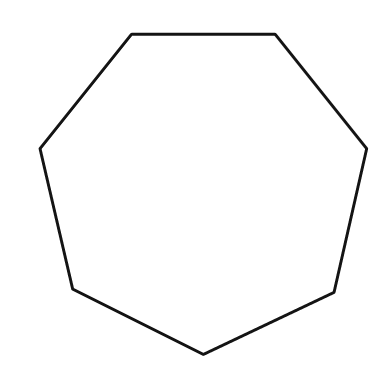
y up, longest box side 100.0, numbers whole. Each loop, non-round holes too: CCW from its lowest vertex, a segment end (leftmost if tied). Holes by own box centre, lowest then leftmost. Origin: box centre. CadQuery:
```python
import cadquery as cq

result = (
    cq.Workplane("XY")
    .moveTo(0.0, -49.0)
    .lineTo(40.0, -30.0)
    .lineTo(50.0, 14.0)
    .lineTo(22.0, 49.0)
    .lineTo(-22.0, 49.0)
    .lineTo(-50.0, 14.0)
    .lineTo(-40.0, -29.0)
    .close()
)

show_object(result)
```